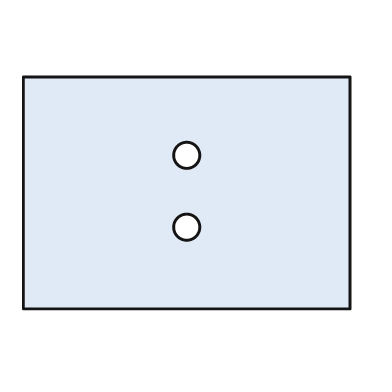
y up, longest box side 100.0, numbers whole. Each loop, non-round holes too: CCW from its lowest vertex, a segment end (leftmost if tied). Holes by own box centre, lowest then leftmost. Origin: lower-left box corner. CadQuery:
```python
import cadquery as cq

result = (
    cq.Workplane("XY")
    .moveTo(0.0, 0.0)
    .lineTo(100.0, 0.0)
    .lineTo(100.0, 71.0)
    .lineTo(0.0, 71.0)
    .close()
    .moveTo(50.0, 25.0)
    .circle(4.0)
    .moveTo(50.0, 47.0)
    .circle(4.0)
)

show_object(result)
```